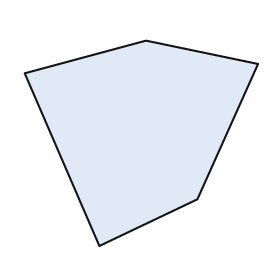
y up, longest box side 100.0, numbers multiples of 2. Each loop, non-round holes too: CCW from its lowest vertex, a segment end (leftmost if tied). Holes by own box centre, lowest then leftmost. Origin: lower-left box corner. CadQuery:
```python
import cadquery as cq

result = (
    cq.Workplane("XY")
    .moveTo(32.0, 0.0)
    .lineTo(74.0, 20.0)
    .lineTo(100.0, 78.0)
    .lineTo(52.0, 88.0)
    .lineTo(0.0, 74.0)
    .close()
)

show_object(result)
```